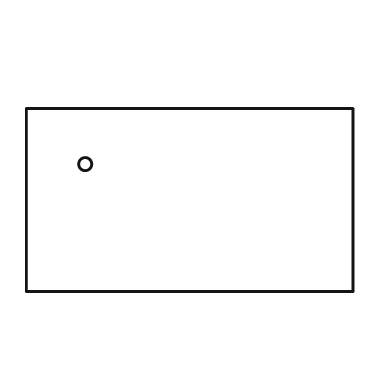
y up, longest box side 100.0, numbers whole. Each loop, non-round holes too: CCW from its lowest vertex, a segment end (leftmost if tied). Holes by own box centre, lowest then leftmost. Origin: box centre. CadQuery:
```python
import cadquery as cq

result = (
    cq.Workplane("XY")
    .moveTo(-50.0, -28.0)
    .lineTo(50.0, -28.0)
    .lineTo(50.0, 28.0)
    .lineTo(-50.0, 28.0)
    .close()
    .moveTo(-32.0, 11.0)
    .circle(2.0)
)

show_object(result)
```